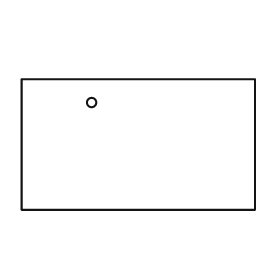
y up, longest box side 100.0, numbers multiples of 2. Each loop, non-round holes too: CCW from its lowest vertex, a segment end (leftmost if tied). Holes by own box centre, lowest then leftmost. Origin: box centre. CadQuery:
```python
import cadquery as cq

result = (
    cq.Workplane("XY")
    .moveTo(-50.0, -28.0)
    .lineTo(50.0, -28.0)
    .lineTo(50.0, 28.0)
    .lineTo(-50.0, 28.0)
    .close()
    .moveTo(-20.0, 18.0)
    .circle(2.0)
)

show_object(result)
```